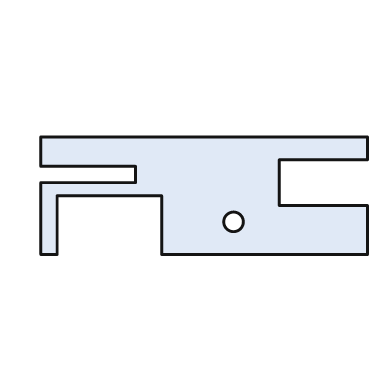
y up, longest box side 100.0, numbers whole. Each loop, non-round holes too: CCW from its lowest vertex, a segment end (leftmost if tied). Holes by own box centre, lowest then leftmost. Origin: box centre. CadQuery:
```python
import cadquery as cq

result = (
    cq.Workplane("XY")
    .moveTo(-50.0, -18.0)
    .lineTo(-45.0, -18.0)
    .lineTo(-45.0, 0.0)
    .lineTo(-13.0, 0.0)
    .lineTo(-13.0, -18.0)
    .lineTo(50.0, -18.0)
    .lineTo(50.0, -3.0)
    .lineTo(23.0, -3.0)
    .lineTo(23.0, 11.0)
    .lineTo(50.0, 11.0)
    .lineTo(50.0, 18.0)
    .lineTo(-50.0, 18.0)
    .lineTo(-50.0, 9.0)
    .lineTo(-21.0, 9.0)
    .lineTo(-21.0, 4.0)
    .lineTo(-50.0, 4.0)
    .close()
    .moveTo(9.0, -8.0)
    .circle(3.0)
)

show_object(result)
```